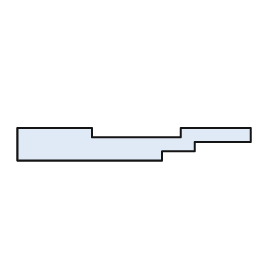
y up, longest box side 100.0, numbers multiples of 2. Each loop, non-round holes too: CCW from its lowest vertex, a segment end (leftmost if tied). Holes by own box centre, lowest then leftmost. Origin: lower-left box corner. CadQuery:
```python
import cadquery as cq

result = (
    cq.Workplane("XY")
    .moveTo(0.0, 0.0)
    .lineTo(62.0, 0.0)
    .lineTo(62.0, 4.0)
    .lineTo(76.0, 4.0)
    .lineTo(76.0, 8.0)
    .lineTo(100.0, 8.0)
    .lineTo(100.0, 14.0)
    .lineTo(70.0, 14.0)
    .lineTo(70.0, 10.0)
    .lineTo(32.0, 10.0)
    .lineTo(32.0, 14.0)
    .lineTo(0.0, 14.0)
    .close()
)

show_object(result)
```